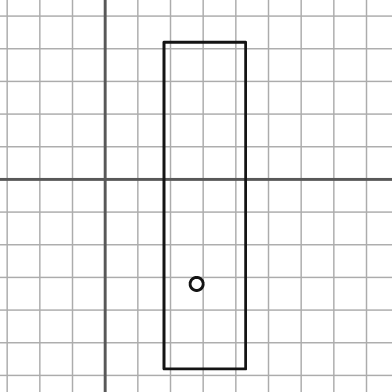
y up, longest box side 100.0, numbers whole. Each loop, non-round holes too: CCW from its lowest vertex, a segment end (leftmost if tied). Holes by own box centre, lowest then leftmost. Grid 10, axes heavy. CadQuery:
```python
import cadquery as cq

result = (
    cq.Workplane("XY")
    .moveTo(18.0, -58.0)
    .lineTo(43.0, -58.0)
    .lineTo(43.0, 42.0)
    .lineTo(18.0, 42.0)
    .close()
    .moveTo(28.0, -32.0)
    .circle(2.0)
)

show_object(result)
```